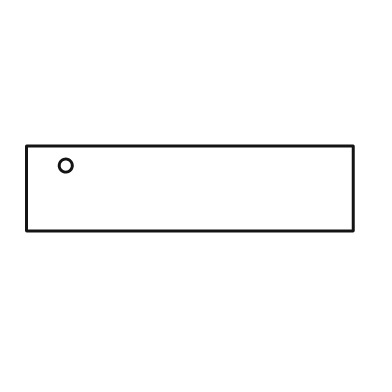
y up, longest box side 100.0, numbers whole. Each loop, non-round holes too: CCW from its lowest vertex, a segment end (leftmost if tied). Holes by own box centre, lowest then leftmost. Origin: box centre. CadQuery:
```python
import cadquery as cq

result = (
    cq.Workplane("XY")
    .moveTo(-50.0, -13.0)
    .lineTo(50.0, -13.0)
    .lineTo(50.0, 13.0)
    .lineTo(-50.0, 13.0)
    .close()
    .moveTo(-38.0, 7.0)
    .circle(2.0)
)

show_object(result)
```